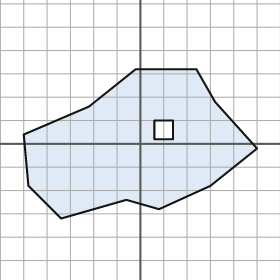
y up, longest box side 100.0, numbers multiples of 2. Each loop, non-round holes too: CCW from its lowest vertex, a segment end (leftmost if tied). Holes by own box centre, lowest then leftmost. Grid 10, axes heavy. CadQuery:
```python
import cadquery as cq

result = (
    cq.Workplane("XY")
    .moveTo(-34.0, -32.0)
    .lineTo(-6.0, -24.0)
    .lineTo(8.0, -28.0)
    .lineTo(30.0, -18.0)
    .lineTo(50.0, -2.0)
    .lineTo(32.0, 18.0)
    .lineTo(24.0, 32.0)
    .lineTo(-2.0, 32.0)
    .lineTo(-22.0, 16.0)
    .lineTo(-50.0, 4.0)
    .lineTo(-48.0, -18.0)
    .close()
    .moveTo(6.0, 2.0)
    .lineTo(14.0, 2.0)
    .lineTo(14.0, 10.0)
    .lineTo(6.0, 10.0)
    .close()
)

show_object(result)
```